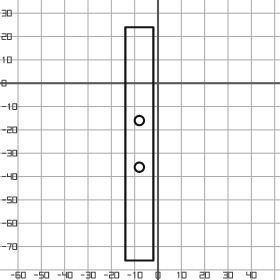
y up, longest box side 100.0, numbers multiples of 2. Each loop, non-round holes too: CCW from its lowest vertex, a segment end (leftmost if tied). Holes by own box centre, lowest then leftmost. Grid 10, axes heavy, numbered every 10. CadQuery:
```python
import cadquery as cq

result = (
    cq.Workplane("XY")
    .moveTo(-14.0, -76.0)
    .lineTo(-2.0, -76.0)
    .lineTo(-2.0, 24.0)
    .lineTo(-14.0, 24.0)
    .close()
    .moveTo(-8.0, -36.0)
    .circle(2.0)
    .moveTo(-8.0, -16.0)
    .circle(2.0)
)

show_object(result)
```